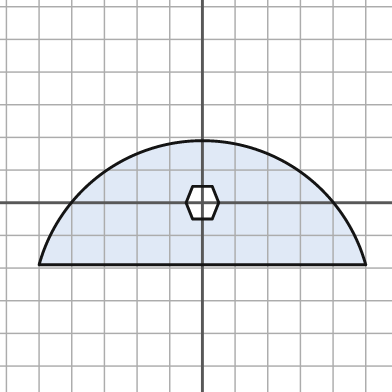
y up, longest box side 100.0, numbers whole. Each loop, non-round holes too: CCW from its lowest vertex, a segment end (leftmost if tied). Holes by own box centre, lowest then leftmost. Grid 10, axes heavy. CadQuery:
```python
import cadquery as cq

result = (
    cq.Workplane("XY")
    .moveTo(-50.0, -19.0)
    .lineTo(50.0, -19.0)
    .threePointArc((0.0, 19.0), (-50.0, -19.0))
    .close()
    .moveTo(-3.0, -5.0)
    .lineTo(3.0, -5.0)
    .lineTo(5.0, 0.0)
    .lineTo(3.0, 5.0)
    .lineTo(-3.0, 5.0)
    .lineTo(-5.0, 0.0)
    .close()
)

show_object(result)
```